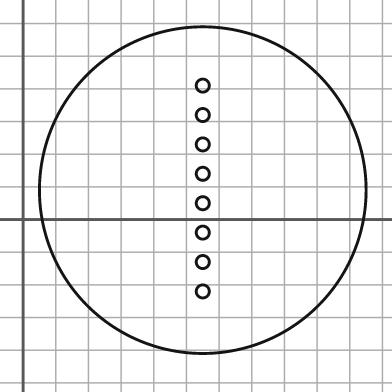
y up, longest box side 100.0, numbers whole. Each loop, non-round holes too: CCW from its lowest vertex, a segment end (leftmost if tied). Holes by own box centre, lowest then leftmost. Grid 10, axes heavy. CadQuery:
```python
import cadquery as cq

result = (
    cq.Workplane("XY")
    .moveTo(55.0, 9.0)
    .circle(50.0)
    .moveTo(55.0, -22.0)
    .circle(2.0)
    .moveTo(55.0, -13.0)
    .circle(2.0)
    .moveTo(55.0, -4.0)
    .circle(2.0)
    .moveTo(55.0, 5.0)
    .circle(2.0)
    .moveTo(55.0, 14.0)
    .circle(2.0)
    .moveTo(55.0, 23.0)
    .circle(2.0)
    .moveTo(55.0, 32.0)
    .circle(2.0)
    .moveTo(55.0, 41.0)
    .circle(2.0)
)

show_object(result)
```